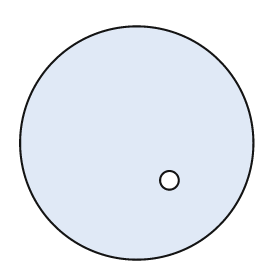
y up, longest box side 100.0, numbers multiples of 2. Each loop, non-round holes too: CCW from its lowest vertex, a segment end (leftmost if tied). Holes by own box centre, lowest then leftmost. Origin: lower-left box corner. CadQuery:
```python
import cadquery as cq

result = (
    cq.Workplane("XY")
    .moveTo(50.0, 50.0)
    .circle(50.0)
    .moveTo(64.0, 34.0)
    .circle(4.0)
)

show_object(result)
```